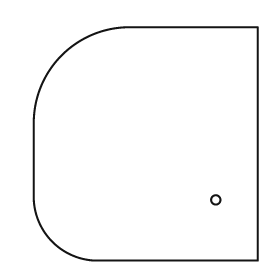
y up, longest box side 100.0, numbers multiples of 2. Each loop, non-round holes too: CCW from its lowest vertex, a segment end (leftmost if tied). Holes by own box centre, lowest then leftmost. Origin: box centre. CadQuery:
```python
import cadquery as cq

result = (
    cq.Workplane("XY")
    .moveTo(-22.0, -50.0)
    .lineTo(48.0, -50.0)
    .lineTo(48.0, 50.0)
    .lineTo(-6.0, 50.0)
    .threePointArc((-36.0, 38.0), (-48.0, 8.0))
    .lineTo(-48.0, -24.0)
    .threePointArc((-40.0, -42.0), (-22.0, -50.0))
    .close()
    .moveTo(30.0, -24.0)
    .circle(2.0)
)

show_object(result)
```